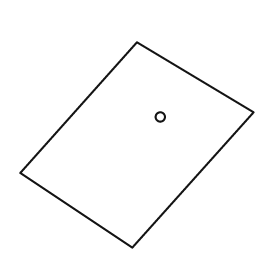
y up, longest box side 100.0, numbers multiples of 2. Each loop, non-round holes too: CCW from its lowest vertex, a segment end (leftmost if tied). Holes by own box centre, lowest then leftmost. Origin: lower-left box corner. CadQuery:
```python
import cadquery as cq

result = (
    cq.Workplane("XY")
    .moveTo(48.0, 0.0)
    .lineTo(100.0, 58.0)
    .lineTo(50.0, 88.0)
    .lineTo(0.0, 32.0)
    .close()
    .moveTo(60.0, 56.0)
    .circle(2.0)
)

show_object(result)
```